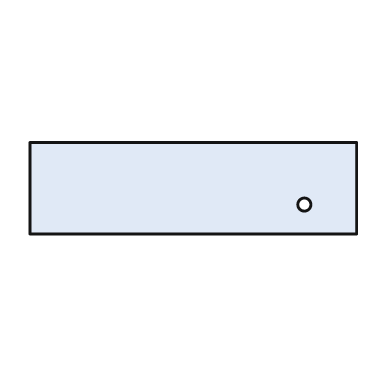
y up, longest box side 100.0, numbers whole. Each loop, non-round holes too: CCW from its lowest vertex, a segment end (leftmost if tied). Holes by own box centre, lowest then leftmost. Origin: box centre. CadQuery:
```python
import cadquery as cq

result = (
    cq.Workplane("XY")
    .moveTo(-50.0, -14.0)
    .lineTo(50.0, -14.0)
    .lineTo(50.0, 14.0)
    .lineTo(-50.0, 14.0)
    .close()
    .moveTo(34.0, -5.0)
    .circle(2.0)
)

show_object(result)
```